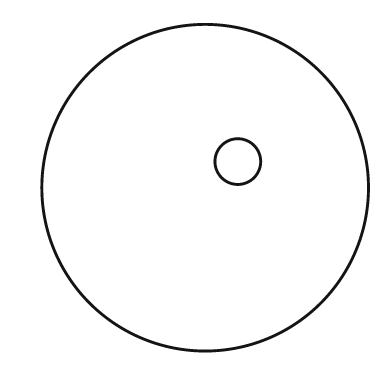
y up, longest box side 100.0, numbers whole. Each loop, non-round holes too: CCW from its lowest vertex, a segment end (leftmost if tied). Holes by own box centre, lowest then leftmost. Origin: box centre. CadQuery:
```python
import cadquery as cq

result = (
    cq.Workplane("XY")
    .moveTo(0.0, 0.0)
    .circle(50.0)
    .moveTo(10.0, 8.0)
    .circle(7.0)
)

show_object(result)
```